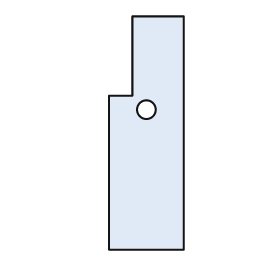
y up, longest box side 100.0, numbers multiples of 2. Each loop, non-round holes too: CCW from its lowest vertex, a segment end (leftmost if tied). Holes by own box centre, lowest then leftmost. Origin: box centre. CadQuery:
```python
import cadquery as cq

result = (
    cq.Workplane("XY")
    .moveTo(-16.0, -50.0)
    .lineTo(16.0, -50.0)
    .lineTo(16.0, 50.0)
    .lineTo(-6.0, 50.0)
    .lineTo(-6.0, 16.0)
    .lineTo(-16.0, 16.0)
    .close()
    .moveTo(0.0, 10.0)
    .circle(4.0)
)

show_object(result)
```